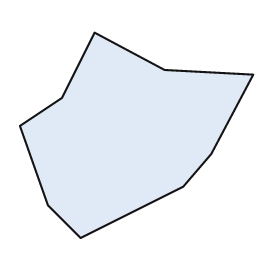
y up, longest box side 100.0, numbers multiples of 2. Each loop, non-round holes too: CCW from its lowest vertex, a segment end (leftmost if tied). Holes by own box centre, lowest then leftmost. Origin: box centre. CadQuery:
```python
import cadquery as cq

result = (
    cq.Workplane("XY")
    .moveTo(-24.0, -44.0)
    .lineTo(20.0, -22.0)
    .lineTo(32.0, -8.0)
    .lineTo(50.0, 26.0)
    .lineTo(12.0, 28.0)
    .lineTo(-18.0, 44.0)
    .lineTo(-32.0, 16.0)
    .lineTo(-50.0, 4.0)
    .lineTo(-38.0, -30.0)
    .close()
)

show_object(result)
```